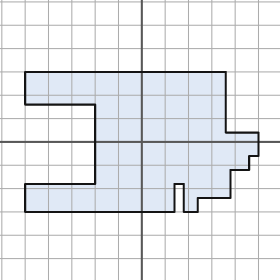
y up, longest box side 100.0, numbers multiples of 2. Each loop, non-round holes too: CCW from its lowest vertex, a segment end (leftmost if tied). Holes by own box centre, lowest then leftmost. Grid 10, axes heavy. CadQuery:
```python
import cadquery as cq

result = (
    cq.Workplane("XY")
    .moveTo(-50.0, -30.0)
    .lineTo(14.0, -30.0)
    .lineTo(14.0, -18.0)
    .lineTo(18.0, -18.0)
    .lineTo(18.0, -30.0)
    .lineTo(24.0, -30.0)
    .lineTo(24.0, -24.0)
    .lineTo(38.0, -24.0)
    .lineTo(38.0, -12.0)
    .lineTo(46.0, -12.0)
    .lineTo(46.0, -6.0)
    .lineTo(50.0, -6.0)
    .lineTo(50.0, 4.0)
    .lineTo(36.0, 4.0)
    .lineTo(36.0, 30.0)
    .lineTo(-50.0, 30.0)
    .lineTo(-50.0, 16.0)
    .lineTo(-20.0, 16.0)
    .lineTo(-20.0, -18.0)
    .lineTo(-50.0, -18.0)
    .close()
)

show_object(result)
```